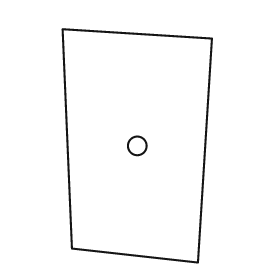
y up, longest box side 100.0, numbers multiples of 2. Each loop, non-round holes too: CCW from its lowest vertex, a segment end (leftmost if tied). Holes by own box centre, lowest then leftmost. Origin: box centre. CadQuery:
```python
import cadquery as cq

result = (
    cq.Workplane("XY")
    .moveTo(26.0, -50.0)
    .lineTo(32.0, 46.0)
    .lineTo(-32.0, 50.0)
    .lineTo(-28.0, -44.0)
    .close()
    .moveTo(0.0, 0.0)
    .circle(4.0)
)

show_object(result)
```